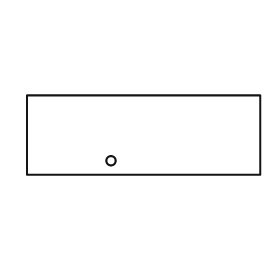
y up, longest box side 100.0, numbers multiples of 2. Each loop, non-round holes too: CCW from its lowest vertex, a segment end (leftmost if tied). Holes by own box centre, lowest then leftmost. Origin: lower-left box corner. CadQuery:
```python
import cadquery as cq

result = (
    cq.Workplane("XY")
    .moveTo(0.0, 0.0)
    .lineTo(100.0, 0.0)
    .lineTo(100.0, 34.0)
    .lineTo(0.0, 34.0)
    .close()
    .moveTo(36.0, 6.0)
    .circle(2.0)
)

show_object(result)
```